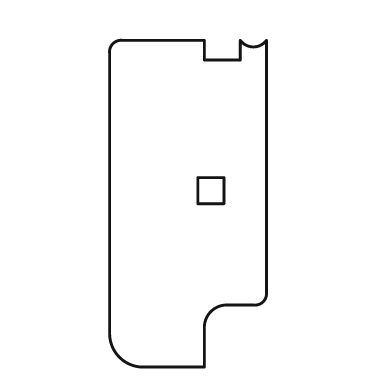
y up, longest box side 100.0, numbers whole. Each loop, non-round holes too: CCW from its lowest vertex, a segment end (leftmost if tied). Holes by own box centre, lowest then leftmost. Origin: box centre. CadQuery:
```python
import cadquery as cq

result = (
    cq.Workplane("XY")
    .moveTo(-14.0, -50.0)
    .lineTo(5.0, -50.0)
    .lineTo(5.0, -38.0)
    .threePointArc((7.0, -33.0), (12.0, -31.0))
    .lineTo(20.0, -31.0)
    .threePointArc((23.0, -30.0), (24.0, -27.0))
    .lineTo(24.0, 50.0)
    .threePointArc((20.0, 48.0), (16.0, 50.0))
    .lineTo(16.0, 44.0)
    .lineTo(5.0, 44.0)
    .lineTo(5.0, 50.0)
    .lineTo(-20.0, 50.0)
    .threePointArc((-23.0, 49.0), (-24.0, 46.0))
    .lineTo(-24.0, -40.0)
    .threePointArc((-21.0, -47.0), (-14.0, -50.0))
    .close()
    .moveTo(3.0, 0.0)
    .lineTo(11.0, 0.0)
    .lineTo(11.0, 8.0)
    .lineTo(3.0, 8.0)
    .close()
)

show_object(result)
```